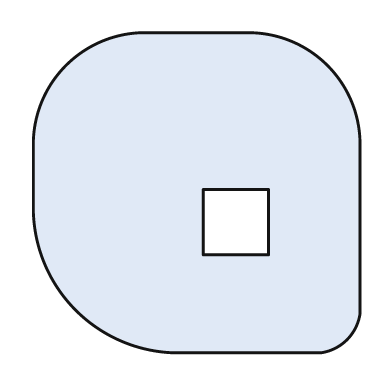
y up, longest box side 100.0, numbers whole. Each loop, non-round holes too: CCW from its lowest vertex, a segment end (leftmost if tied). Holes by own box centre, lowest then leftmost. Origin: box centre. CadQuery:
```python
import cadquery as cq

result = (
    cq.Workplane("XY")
    .moveTo(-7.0, -49.0)
    .lineTo(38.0, -49.0)
    .threePointArc((46.0, -45.0), (50.0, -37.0))
    .lineTo(50.0, 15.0)
    .threePointArc((40.0, 39.0), (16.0, 49.0))
    .lineTo(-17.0, 49.0)
    .threePointArc((-40.0, 39.0), (-50.0, 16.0))
    .lineTo(-50.0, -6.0)
    .threePointArc((-37.0, -36.0), (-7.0, -49.0))
    .close()
    .moveTo(2.0, -19.0)
    .lineTo(22.0, -19.0)
    .lineTo(22.0, 1.0)
    .lineTo(2.0, 1.0)
    .close()
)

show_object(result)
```